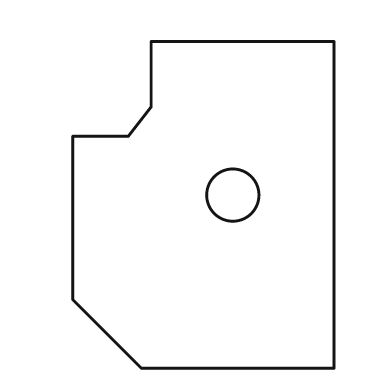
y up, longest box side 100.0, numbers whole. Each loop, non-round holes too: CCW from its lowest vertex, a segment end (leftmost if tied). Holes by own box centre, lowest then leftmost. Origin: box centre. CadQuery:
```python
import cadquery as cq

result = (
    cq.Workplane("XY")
    .moveTo(-19.0, -50.0)
    .lineTo(40.0, -50.0)
    .lineTo(40.0, 50.0)
    .lineTo(-16.0, 50.0)
    .lineTo(-16.0, 30.0)
    .lineTo(-23.0, 21.0)
    .lineTo(-40.0, 21.0)
    .lineTo(-40.0, -29.0)
    .close()
    .moveTo(9.0, 3.0)
    .circle(8.0)
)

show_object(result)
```